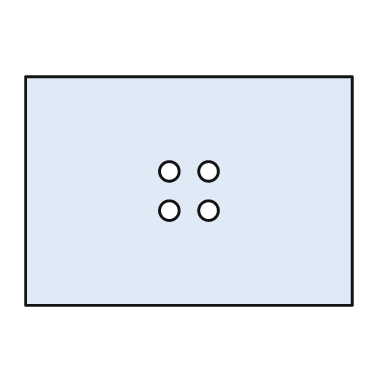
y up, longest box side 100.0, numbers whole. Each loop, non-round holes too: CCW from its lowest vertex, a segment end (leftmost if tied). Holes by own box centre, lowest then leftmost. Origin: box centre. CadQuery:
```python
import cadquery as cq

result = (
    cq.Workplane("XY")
    .moveTo(-50.0, -35.0)
    .lineTo(50.0, -35.0)
    .lineTo(50.0, 35.0)
    .lineTo(-50.0, 35.0)
    .close()
    .moveTo(-6.0, -6.0)
    .circle(3.0)
    .moveTo(6.0, -6.0)
    .circle(3.0)
    .moveTo(-6.0, 6.0)
    .circle(3.0)
    .moveTo(6.0, 6.0)
    .circle(3.0)
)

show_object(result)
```